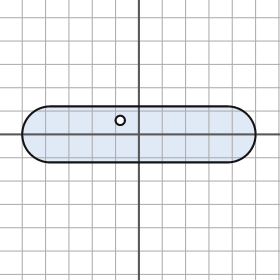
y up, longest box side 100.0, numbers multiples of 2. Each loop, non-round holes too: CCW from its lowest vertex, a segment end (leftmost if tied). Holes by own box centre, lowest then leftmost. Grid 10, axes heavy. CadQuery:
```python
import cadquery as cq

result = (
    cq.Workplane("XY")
    .moveTo(-38.0, -12.0)
    .lineTo(38.0, -12.0)
    .threePointArc((50.0, 0.0), (38.0, 12.0))
    .lineTo(-38.0, 12.0)
    .threePointArc((-50.0, 0.0), (-38.0, -12.0))
    .close()
    .moveTo(-8.0, 6.0)
    .circle(2.0)
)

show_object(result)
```